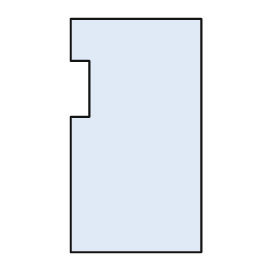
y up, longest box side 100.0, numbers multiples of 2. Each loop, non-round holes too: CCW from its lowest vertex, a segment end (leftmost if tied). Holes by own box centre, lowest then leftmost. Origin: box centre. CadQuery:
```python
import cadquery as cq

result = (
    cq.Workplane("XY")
    .moveTo(-28.0, -50.0)
    .lineTo(28.0, -50.0)
    .lineTo(28.0, 50.0)
    .lineTo(-28.0, 50.0)
    .lineTo(-28.0, 32.0)
    .lineTo(-20.0, 32.0)
    .lineTo(-20.0, 8.0)
    .lineTo(-28.0, 8.0)
    .close()
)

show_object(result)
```